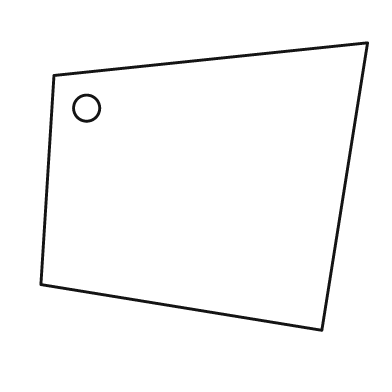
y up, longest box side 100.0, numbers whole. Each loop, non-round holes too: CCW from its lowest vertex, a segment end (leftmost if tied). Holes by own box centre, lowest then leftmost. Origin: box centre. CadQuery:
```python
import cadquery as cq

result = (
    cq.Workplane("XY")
    .moveTo(36.0, -44.0)
    .lineTo(50.0, 44.0)
    .lineTo(-46.0, 34.0)
    .lineTo(-50.0, -30.0)
    .close()
    .moveTo(-36.0, 24.0)
    .circle(4.0)
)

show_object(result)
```